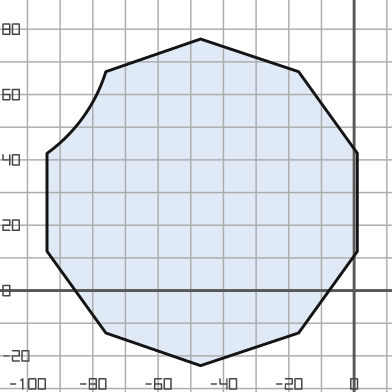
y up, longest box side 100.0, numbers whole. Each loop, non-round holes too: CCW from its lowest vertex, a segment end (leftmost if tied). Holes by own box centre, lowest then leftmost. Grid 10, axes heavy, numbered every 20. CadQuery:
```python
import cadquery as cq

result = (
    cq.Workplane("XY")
    .moveTo(-47.0, -23.0)
    .lineTo(-17.0, -13.0)
    .lineTo(1.0, 12.0)
    .lineTo(1.0, 42.0)
    .lineTo(-17.0, 67.0)
    .lineTo(-47.0, 77.0)
    .lineTo(-76.0, 67.0)
    .threePointArc((-83.0, 53.0), (-94.0, 42.0))
    .lineTo(-94.0, 12.0)
    .lineTo(-76.0, -13.0)
    .close()
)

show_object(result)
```